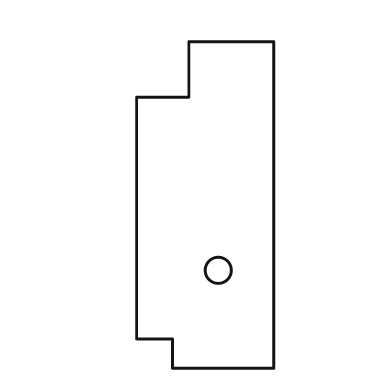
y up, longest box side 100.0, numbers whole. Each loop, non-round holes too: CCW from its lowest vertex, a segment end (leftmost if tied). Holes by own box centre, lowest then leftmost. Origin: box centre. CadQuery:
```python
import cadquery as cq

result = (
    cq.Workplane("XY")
    .moveTo(-10.0, -50.0)
    .lineTo(21.0, -50.0)
    .lineTo(21.0, 50.0)
    .lineTo(-5.0, 50.0)
    .lineTo(-5.0, 33.0)
    .lineTo(-21.0, 33.0)
    .lineTo(-21.0, -41.0)
    .lineTo(-10.0, -41.0)
    .close()
    .moveTo(4.0, -20.0)
    .circle(4.0)
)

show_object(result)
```